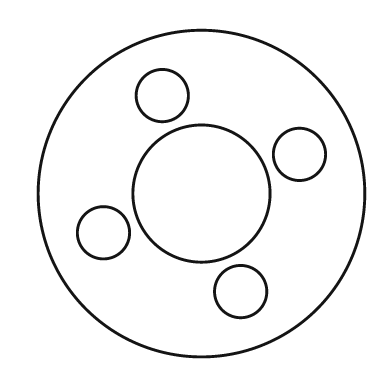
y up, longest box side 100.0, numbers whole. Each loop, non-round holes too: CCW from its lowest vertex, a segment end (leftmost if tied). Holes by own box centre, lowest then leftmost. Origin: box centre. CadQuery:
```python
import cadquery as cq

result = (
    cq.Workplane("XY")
    .moveTo(0.0, 0.0)
    .circle(50.0)
    .moveTo(12.0, -30.0)
    .circle(8.0)
    .moveTo(-30.0, -12.0)
    .circle(8.0)
    .moveTo(0.0, 0.0)
    .circle(21.0)
    .moveTo(30.0, 12.0)
    .circle(8.0)
    .moveTo(-12.0, 30.0)
    .circle(8.0)
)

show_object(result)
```